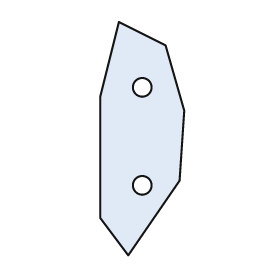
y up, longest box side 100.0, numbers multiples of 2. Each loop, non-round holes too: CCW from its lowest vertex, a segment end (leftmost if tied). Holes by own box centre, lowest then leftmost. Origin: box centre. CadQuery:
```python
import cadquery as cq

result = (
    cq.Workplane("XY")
    .moveTo(-6.0, -50.0)
    .lineTo(16.0, -18.0)
    .lineTo(18.0, 12.0)
    .lineTo(10.0, 40.0)
    .lineTo(-10.0, 50.0)
    .lineTo(-18.0, 18.0)
    .lineTo(-18.0, -34.0)
    .close()
    .moveTo(0.0, -20.0)
    .circle(4.0)
    .moveTo(0.0, 22.0)
    .circle(4.0)
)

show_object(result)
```